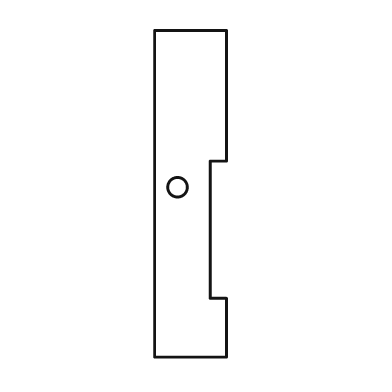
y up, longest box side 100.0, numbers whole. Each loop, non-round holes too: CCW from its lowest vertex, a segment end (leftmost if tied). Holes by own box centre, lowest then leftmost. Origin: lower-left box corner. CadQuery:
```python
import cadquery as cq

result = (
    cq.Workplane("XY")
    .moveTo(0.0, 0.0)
    .lineTo(22.0, 0.0)
    .lineTo(22.0, 18.0)
    .lineTo(17.0, 18.0)
    .lineTo(17.0, 60.0)
    .lineTo(22.0, 60.0)
    .lineTo(22.0, 100.0)
    .lineTo(0.0, 100.0)
    .close()
    .moveTo(7.0, 52.0)
    .circle(3.0)
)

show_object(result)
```